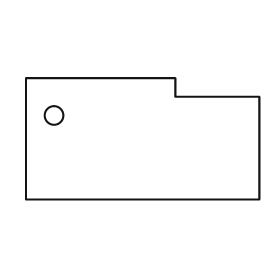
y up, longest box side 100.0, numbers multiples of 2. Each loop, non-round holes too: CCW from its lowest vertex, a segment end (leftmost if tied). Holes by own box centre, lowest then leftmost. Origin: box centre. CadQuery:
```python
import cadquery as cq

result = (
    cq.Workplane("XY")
    .moveTo(-50.0, -26.0)
    .lineTo(50.0, -26.0)
    .lineTo(50.0, 18.0)
    .lineTo(14.0, 18.0)
    .lineTo(14.0, 26.0)
    .lineTo(-50.0, 26.0)
    .close()
    .moveTo(-38.0, 10.0)
    .circle(4.0)
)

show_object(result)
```